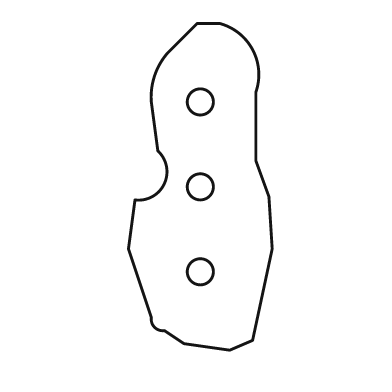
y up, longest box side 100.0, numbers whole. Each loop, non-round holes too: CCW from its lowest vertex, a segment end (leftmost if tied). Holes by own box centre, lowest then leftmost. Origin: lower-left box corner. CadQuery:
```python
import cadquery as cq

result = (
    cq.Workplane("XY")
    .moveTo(31.0, 0.0)
    .lineTo(38.0, 3.0)
    .lineTo(44.0, 31.0)
    .lineTo(43.0, 47.0)
    .lineTo(39.0, 58.0)
    .lineTo(39.0, 79.0)
    .threePointArc((38.0, 92.0), (28.0, 100.0))
    .lineTo(21.0, 100.0)
    .lineTo(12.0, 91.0)
    .threePointArc((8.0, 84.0), (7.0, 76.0))
    .lineTo(9.0, 61.0)
    .threePointArc((11.0, 51.0), (2.0, 46.0))
    .lineTo(0.0, 31.0)
    .lineTo(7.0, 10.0)
    .threePointArc((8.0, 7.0), (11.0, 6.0))
    .lineTo(17.0, 2.0)
    .close()
    .moveTo(22.0, 24.0)
    .circle(4.0)
    .moveTo(22.0, 50.0)
    .circle(4.0)
    .moveTo(22.0, 76.0)
    .circle(4.0)
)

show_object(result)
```